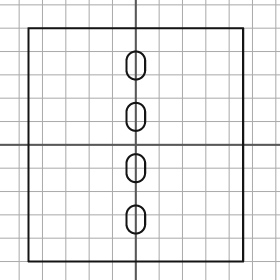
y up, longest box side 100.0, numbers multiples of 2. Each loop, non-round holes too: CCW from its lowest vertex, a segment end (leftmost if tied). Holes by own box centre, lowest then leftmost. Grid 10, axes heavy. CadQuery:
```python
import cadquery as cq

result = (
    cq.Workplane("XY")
    .moveTo(-46.0, -50.0)
    .lineTo(46.0, -50.0)
    .lineTo(46.0, 50.0)
    .lineTo(-46.0, 50.0)
    .close()
    .moveTo(-4.0, -34.0)
    .threePointArc((0.0, -38.0), (4.0, -34.0))
    .lineTo(4.0, -30.0)
    .threePointArc((0.0, -26.0), (-4.0, -30.0))
    .close()
    .moveTo(-4.0, -12.0)
    .threePointArc((0.0, -16.0), (4.0, -12.0))
    .lineTo(4.0, -8.0)
    .threePointArc((0.0, -4.0), (-4.0, -8.0))
    .close()
    .moveTo(-4.0, 10.0)
    .threePointArc((0.0, 6.0), (4.0, 10.0))
    .lineTo(4.0, 14.0)
    .threePointArc((0.0, 18.0), (-4.0, 14.0))
    .close()
    .moveTo(-4.0, 32.0)
    .threePointArc((0.0, 28.0), (4.0, 32.0))
    .lineTo(4.0, 36.0)
    .threePointArc((0.0, 40.0), (-4.0, 36.0))
    .close()
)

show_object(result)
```